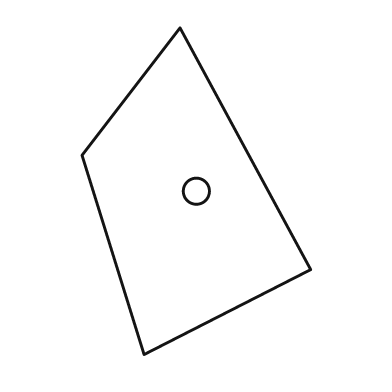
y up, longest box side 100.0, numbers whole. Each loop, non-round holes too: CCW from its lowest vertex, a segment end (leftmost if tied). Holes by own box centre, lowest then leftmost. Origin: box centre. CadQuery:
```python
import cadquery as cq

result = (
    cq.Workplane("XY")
    .moveTo(-16.0, -50.0)
    .lineTo(35.0, -24.0)
    .lineTo(-5.0, 50.0)
    .lineTo(-35.0, 11.0)
    .close()
    .moveTo(0.0, 0.0)
    .circle(4.0)
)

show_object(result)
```